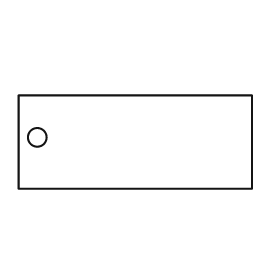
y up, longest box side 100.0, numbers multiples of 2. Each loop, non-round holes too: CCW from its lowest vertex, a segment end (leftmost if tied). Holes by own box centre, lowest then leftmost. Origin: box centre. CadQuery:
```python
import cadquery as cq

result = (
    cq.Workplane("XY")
    .moveTo(-50.0, -20.0)
    .lineTo(50.0, -20.0)
    .lineTo(50.0, 20.0)
    .lineTo(-50.0, 20.0)
    .close()
    .moveTo(-42.0, 2.0)
    .circle(4.0)
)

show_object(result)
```